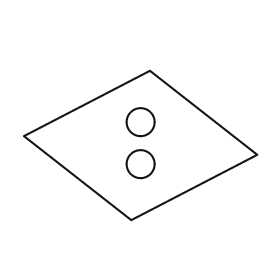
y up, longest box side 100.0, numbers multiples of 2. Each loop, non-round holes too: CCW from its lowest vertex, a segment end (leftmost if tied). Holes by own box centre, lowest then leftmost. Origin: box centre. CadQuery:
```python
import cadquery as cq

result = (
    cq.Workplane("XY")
    .moveTo(-4.0, -32.0)
    .lineTo(50.0, -4.0)
    .lineTo(4.0, 32.0)
    .lineTo(-50.0, 4.0)
    .close()
    .moveTo(0.0, -8.0)
    .circle(6.0)
    .moveTo(0.0, 10.0)
    .circle(6.0)
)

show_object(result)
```